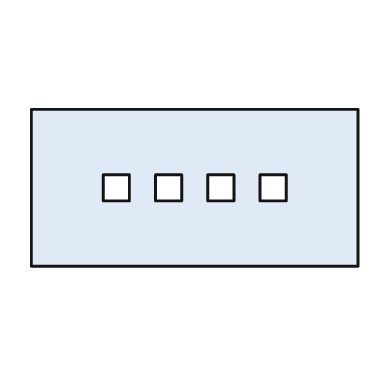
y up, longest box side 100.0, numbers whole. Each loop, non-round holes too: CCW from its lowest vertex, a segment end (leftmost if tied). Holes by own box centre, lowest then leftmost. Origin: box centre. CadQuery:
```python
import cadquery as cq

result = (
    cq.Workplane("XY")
    .moveTo(-50.0, -24.0)
    .lineTo(50.0, -24.0)
    .lineTo(50.0, 24.0)
    .lineTo(-50.0, 24.0)
    .close()
    .moveTo(-28.0, -4.0)
    .lineTo(-20.0, -4.0)
    .lineTo(-20.0, 4.0)
    .lineTo(-28.0, 4.0)
    .close()
    .moveTo(-12.0, -4.0)
    .lineTo(-4.0, -4.0)
    .lineTo(-4.0, 4.0)
    .lineTo(-12.0, 4.0)
    .close()
    .moveTo(4.0, -4.0)
    .lineTo(12.0, -4.0)
    .lineTo(12.0, 4.0)
    .lineTo(4.0, 4.0)
    .close()
    .moveTo(20.0, -4.0)
    .lineTo(28.0, -4.0)
    .lineTo(28.0, 4.0)
    .lineTo(20.0, 4.0)
    .close()
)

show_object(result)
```